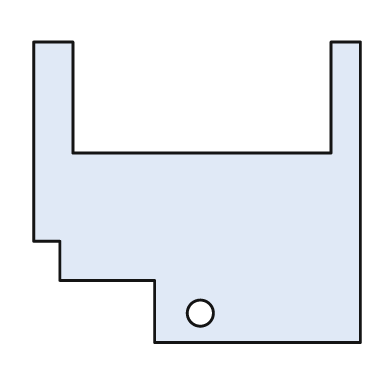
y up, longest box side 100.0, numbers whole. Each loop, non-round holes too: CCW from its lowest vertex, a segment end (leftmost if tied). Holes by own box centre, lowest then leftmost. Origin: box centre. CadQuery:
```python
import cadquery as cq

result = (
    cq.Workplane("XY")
    .moveTo(-13.0, -46.0)
    .lineTo(50.0, -46.0)
    .lineTo(50.0, 46.0)
    .lineTo(41.0, 46.0)
    .lineTo(41.0, 12.0)
    .lineTo(-38.0, 12.0)
    .lineTo(-38.0, 46.0)
    .lineTo(-50.0, 46.0)
    .lineTo(-50.0, -15.0)
    .lineTo(-42.0, -15.0)
    .lineTo(-42.0, -27.0)
    .lineTo(-13.0, -27.0)
    .close()
    .moveTo(1.0, -37.0)
    .circle(4.0)
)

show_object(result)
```